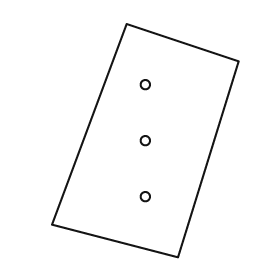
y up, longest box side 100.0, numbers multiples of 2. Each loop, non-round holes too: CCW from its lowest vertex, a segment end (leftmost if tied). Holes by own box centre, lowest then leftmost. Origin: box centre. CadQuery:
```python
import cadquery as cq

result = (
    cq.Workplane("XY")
    .moveTo(14.0, -50.0)
    .lineTo(40.0, 34.0)
    .lineTo(-8.0, 50.0)
    .lineTo(-40.0, -36.0)
    .close()
    .moveTo(0.0, -24.0)
    .circle(2.0)
    .moveTo(0.0, 0.0)
    .circle(2.0)
    .moveTo(0.0, 24.0)
    .circle(2.0)
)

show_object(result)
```